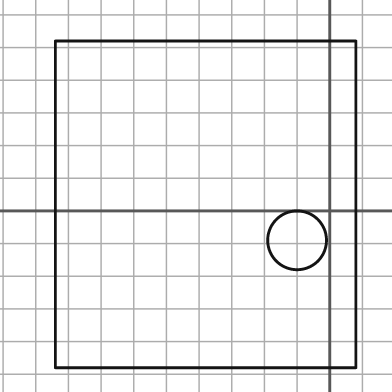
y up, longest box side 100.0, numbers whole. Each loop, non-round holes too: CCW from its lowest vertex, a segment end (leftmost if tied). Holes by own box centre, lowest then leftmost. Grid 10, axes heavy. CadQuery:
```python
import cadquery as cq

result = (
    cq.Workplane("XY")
    .moveTo(-84.0, -48.0)
    .lineTo(8.0, -48.0)
    .lineTo(8.0, 52.0)
    .lineTo(-84.0, 52.0)
    .close()
    .moveTo(-10.0, -9.0)
    .circle(9.0)
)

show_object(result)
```